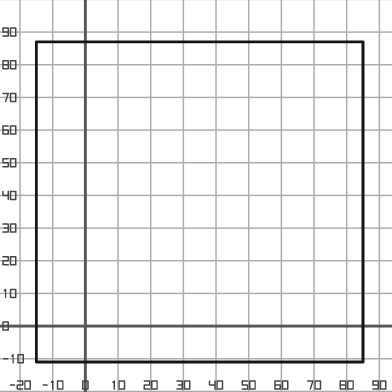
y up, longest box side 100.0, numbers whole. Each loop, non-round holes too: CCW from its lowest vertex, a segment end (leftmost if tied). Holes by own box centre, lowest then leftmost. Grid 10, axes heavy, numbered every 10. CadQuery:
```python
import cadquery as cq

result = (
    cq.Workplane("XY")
    .moveTo(-15.0, -11.0)
    .lineTo(85.0, -11.0)
    .lineTo(85.0, 87.0)
    .lineTo(-15.0, 87.0)
    .close()
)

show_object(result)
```